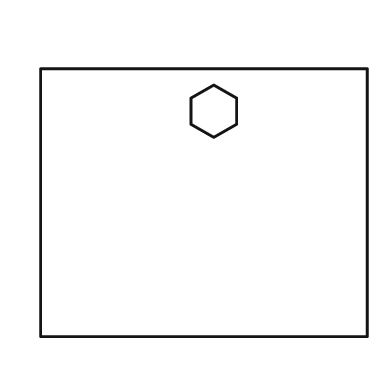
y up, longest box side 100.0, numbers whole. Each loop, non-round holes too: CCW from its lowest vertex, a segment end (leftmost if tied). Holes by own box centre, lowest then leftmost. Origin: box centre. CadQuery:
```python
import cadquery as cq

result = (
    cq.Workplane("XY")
    .moveTo(-50.0, -41.0)
    .lineTo(50.0, -41.0)
    .lineTo(50.0, 41.0)
    .lineTo(-50.0, 41.0)
    .close()
    .moveTo(3.0, 20.0)
    .lineTo(10.0, 24.0)
    .lineTo(10.0, 32.0)
    .lineTo(3.0, 36.0)
    .lineTo(-4.0, 32.0)
    .lineTo(-4.0, 24.0)
    .close()
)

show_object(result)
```